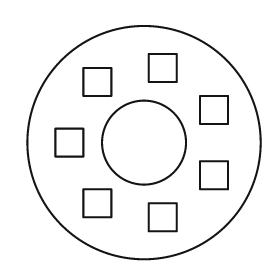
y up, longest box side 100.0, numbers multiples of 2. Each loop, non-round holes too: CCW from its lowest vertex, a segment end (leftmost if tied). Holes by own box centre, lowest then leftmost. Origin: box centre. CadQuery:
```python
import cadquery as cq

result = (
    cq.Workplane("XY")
    .moveTo(0.0, 0.0)
    .circle(50.0)
    .moveTo(2.0, -38.0)
    .lineTo(14.0, -38.0)
    .lineTo(14.0, -26.0)
    .lineTo(2.0, -26.0)
    .close()
    .moveTo(-26.0, -32.0)
    .lineTo(-14.0, -32.0)
    .lineTo(-14.0, -20.0)
    .lineTo(-26.0, -20.0)
    .close()
    .moveTo(24.0, -20.0)
    .lineTo(36.0, -20.0)
    .lineTo(36.0, -8.0)
    .lineTo(24.0, -8.0)
    .close()
    .moveTo(-38.0, -6.0)
    .lineTo(-26.0, -6.0)
    .lineTo(-26.0, 6.0)
    .lineTo(-38.0, 6.0)
    .close()
    .moveTo(0.0, 0.0)
    .circle(18.0)
    .moveTo(24.0, 8.0)
    .lineTo(36.0, 8.0)
    .lineTo(36.0, 20.0)
    .lineTo(24.0, 20.0)
    .close()
    .moveTo(-26.0, 20.0)
    .lineTo(-14.0, 20.0)
    .lineTo(-14.0, 32.0)
    .lineTo(-26.0, 32.0)
    .close()
    .moveTo(2.0, 26.0)
    .lineTo(14.0, 26.0)
    .lineTo(14.0, 38.0)
    .lineTo(2.0, 38.0)
    .close()
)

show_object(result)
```